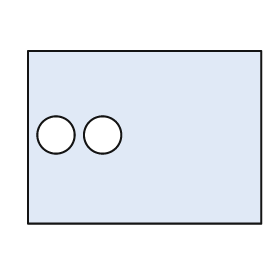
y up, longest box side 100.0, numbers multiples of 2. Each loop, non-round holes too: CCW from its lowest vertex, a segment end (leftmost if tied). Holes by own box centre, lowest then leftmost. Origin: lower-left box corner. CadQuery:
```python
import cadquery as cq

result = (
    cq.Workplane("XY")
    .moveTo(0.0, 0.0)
    .lineTo(100.0, 0.0)
    .lineTo(100.0, 74.0)
    .lineTo(0.0, 74.0)
    .close()
    .moveTo(12.0, 38.0)
    .circle(8.0)
    .moveTo(32.0, 38.0)
    .circle(8.0)
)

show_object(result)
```